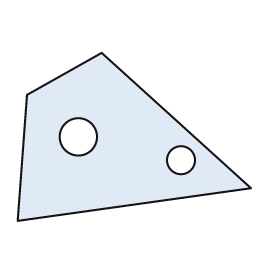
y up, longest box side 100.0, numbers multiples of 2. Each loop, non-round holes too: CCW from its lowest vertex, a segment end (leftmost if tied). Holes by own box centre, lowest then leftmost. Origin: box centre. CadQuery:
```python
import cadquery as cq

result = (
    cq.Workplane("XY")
    .moveTo(-50.0, -36.0)
    .lineTo(50.0, -22.0)
    .lineTo(-14.0, 36.0)
    .lineTo(-46.0, 18.0)
    .close()
    .moveTo(20.0, -10.0)
    .circle(6.0)
    .moveTo(-24.0, 0.0)
    .circle(8.0)
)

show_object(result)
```